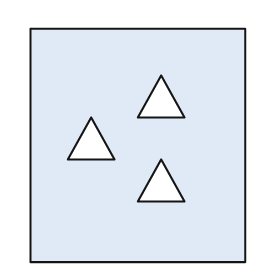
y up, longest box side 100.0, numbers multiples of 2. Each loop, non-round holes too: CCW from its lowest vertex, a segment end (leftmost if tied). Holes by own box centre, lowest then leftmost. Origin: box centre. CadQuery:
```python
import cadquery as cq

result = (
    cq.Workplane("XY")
    .moveTo(-46.0, -50.0)
    .lineTo(46.0, -50.0)
    .lineTo(46.0, 50.0)
    .lineTo(-46.0, 50.0)
    .close()
    .moveTo(0.0, -24.0)
    .lineTo(20.0, -24.0)
    .lineTo(10.0, -6.0)
    .close()
    .moveTo(-30.0, -6.0)
    .lineTo(-10.0, -6.0)
    .lineTo(-20.0, 12.0)
    .close()
    .moveTo(0.0, 12.0)
    .lineTo(20.0, 12.0)
    .lineTo(10.0, 30.0)
    .close()
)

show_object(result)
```